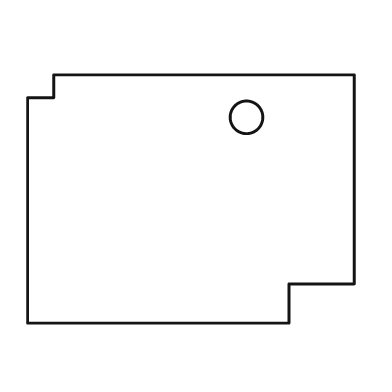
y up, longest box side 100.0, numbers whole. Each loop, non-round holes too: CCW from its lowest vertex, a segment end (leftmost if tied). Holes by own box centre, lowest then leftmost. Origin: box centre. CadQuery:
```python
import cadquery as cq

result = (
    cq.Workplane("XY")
    .moveTo(-50.0, -38.0)
    .lineTo(30.0, -38.0)
    .lineTo(30.0, -26.0)
    .lineTo(50.0, -26.0)
    .lineTo(50.0, 38.0)
    .lineTo(-42.0, 38.0)
    .lineTo(-42.0, 31.0)
    .lineTo(-50.0, 31.0)
    .close()
    .moveTo(17.0, 25.0)
    .circle(5.0)
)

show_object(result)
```